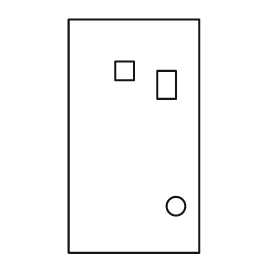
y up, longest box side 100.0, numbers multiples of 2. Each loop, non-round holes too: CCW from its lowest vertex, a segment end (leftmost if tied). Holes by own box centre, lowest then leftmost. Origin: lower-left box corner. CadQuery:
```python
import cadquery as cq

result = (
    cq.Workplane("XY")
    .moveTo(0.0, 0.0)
    .lineTo(56.0, 0.0)
    .lineTo(56.0, 100.0)
    .lineTo(0.0, 100.0)
    .close()
    .moveTo(46.0, 20.0)
    .circle(4.0)
    .moveTo(38.0, 66.0)
    .lineTo(46.0, 66.0)
    .lineTo(46.0, 78.0)
    .lineTo(38.0, 78.0)
    .close()
    .moveTo(20.0, 74.0)
    .lineTo(28.0, 74.0)
    .lineTo(28.0, 82.0)
    .lineTo(20.0, 82.0)
    .close()
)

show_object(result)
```